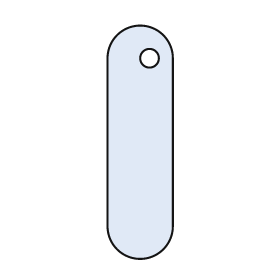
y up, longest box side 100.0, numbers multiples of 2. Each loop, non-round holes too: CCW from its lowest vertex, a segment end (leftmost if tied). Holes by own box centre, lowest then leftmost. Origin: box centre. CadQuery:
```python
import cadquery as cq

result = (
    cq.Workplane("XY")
    .moveTo(-14.0, -36.0)
    .threePointArc((0.0, -50.0), (14.0, -36.0))
    .lineTo(14.0, 36.0)
    .threePointArc((0.0, 50.0), (-14.0, 36.0))
    .close()
    .moveTo(4.0, 36.0)
    .circle(4.0)
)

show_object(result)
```